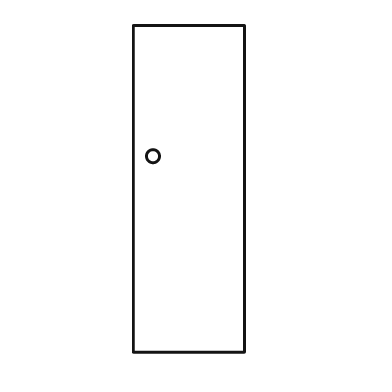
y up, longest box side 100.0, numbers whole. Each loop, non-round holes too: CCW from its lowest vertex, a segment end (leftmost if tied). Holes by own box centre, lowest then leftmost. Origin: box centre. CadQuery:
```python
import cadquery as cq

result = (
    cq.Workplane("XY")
    .moveTo(-17.0, -50.0)
    .lineTo(17.0, -50.0)
    .lineTo(17.0, 50.0)
    .lineTo(-17.0, 50.0)
    .close()
    .moveTo(-11.0, 10.0)
    .circle(2.0)
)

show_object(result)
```